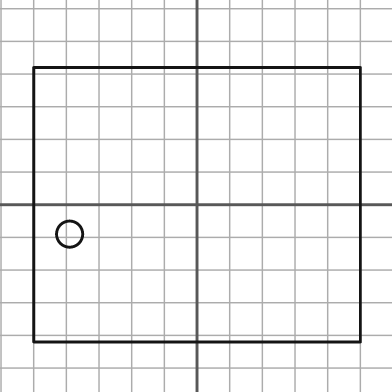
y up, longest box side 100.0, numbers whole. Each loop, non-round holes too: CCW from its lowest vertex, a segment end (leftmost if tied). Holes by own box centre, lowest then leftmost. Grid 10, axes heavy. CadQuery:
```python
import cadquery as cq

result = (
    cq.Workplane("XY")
    .moveTo(-50.0, -42.0)
    .lineTo(50.0, -42.0)
    .lineTo(50.0, 42.0)
    .lineTo(-50.0, 42.0)
    .close()
    .moveTo(-39.0, -9.0)
    .circle(4.0)
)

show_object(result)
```